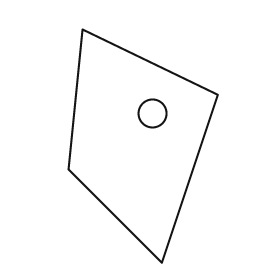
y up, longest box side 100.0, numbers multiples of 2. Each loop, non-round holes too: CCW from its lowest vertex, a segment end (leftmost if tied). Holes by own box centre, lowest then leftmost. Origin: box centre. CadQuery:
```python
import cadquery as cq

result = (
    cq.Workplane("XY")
    .moveTo(8.0, -50.0)
    .lineTo(32.0, 22.0)
    .lineTo(-26.0, 50.0)
    .lineTo(-32.0, -10.0)
    .close()
    .moveTo(4.0, 14.0)
    .circle(6.0)
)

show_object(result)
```